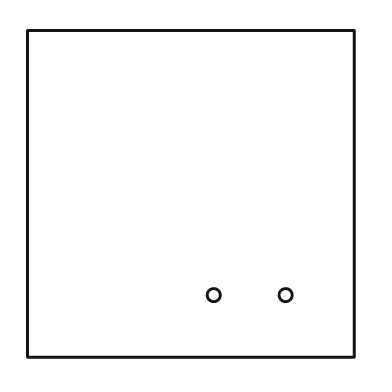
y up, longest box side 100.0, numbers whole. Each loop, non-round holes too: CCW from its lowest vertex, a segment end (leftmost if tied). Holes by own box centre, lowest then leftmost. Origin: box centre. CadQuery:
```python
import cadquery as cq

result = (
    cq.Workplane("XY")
    .moveTo(-50.0, -50.0)
    .lineTo(50.0, -50.0)
    .lineTo(50.0, 50.0)
    .lineTo(-50.0, 50.0)
    .close()
    .moveTo(7.0, -31.0)
    .circle(2.0)
    .moveTo(29.0, -31.0)
    .circle(2.0)
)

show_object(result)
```